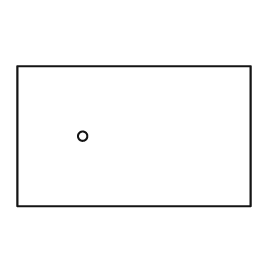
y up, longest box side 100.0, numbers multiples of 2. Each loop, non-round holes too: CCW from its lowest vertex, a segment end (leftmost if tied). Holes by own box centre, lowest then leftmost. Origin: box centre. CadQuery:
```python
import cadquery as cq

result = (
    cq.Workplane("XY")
    .moveTo(-50.0, -30.0)
    .lineTo(50.0, -30.0)
    .lineTo(50.0, 30.0)
    .lineTo(-50.0, 30.0)
    .close()
    .moveTo(-22.0, 0.0)
    .circle(2.0)
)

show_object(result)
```